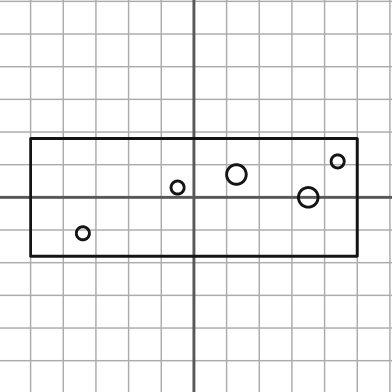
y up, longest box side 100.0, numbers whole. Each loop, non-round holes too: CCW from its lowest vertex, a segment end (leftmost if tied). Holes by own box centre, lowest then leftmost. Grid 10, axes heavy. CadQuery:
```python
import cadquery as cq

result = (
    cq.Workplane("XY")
    .moveTo(-50.0, -18.0)
    .lineTo(50.0, -18.0)
    .lineTo(50.0, 18.0)
    .lineTo(-50.0, 18.0)
    .close()
    .moveTo(-34.0, -11.0)
    .circle(2.0)
    .moveTo(35.0, 0.0)
    .circle(3.0)
    .moveTo(-5.0, 3.0)
    .circle(2.0)
    .moveTo(13.0, 7.0)
    .circle(3.0)
    .moveTo(44.0, 11.0)
    .circle(2.0)
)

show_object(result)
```